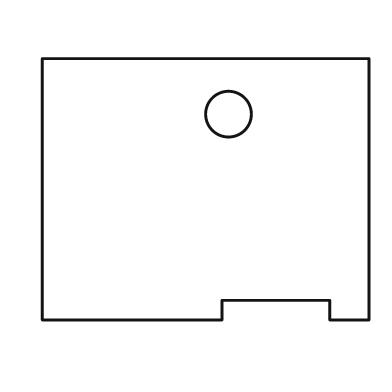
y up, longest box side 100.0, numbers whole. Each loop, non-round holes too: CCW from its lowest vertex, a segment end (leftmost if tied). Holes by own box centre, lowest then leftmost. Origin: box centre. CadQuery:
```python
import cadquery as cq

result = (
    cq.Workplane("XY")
    .moveTo(-50.0, -40.0)
    .lineTo(5.0, -40.0)
    .lineTo(5.0, -34.0)
    .lineTo(38.0, -34.0)
    .lineTo(38.0, -40.0)
    .lineTo(50.0, -40.0)
    .lineTo(50.0, 40.0)
    .lineTo(-50.0, 40.0)
    .close()
    .moveTo(7.0, 23.0)
    .circle(7.0)
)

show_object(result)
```